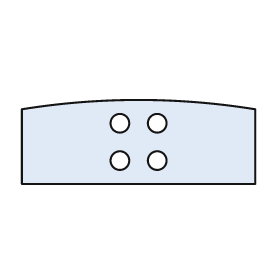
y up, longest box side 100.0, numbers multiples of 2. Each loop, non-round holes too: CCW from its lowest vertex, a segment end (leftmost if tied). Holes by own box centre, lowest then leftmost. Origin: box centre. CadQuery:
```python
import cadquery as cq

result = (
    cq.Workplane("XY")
    .moveTo(-50.0, -18.0)
    .lineTo(50.0, -18.0)
    .lineTo(50.0, 14.0)
    .threePointArc((0.0, 18.0), (-50.0, 14.0))
    .close()
    .moveTo(-8.0, -8.0)
    .circle(4.0)
    .moveTo(8.0, -8.0)
    .circle(4.0)
    .moveTo(-8.0, 8.0)
    .circle(4.0)
    .moveTo(8.0, 8.0)
    .circle(4.0)
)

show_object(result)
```